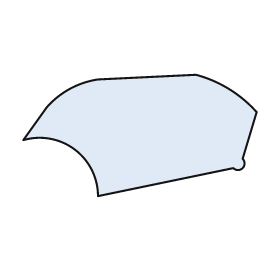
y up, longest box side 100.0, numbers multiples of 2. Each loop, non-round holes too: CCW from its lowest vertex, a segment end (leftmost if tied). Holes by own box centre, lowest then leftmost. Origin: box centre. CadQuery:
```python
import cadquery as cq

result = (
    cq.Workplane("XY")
    .moveTo(-18.0, -26.0)
    .lineTo(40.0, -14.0)
    .threePointArc((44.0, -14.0), (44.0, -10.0))
    .lineTo(50.0, 10.0)
    .threePointArc((38.0, 20.0), (24.0, 26.0))
    .lineTo(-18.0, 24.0)
    .threePointArc((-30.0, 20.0), (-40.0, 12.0))
    .lineTo(-50.0, -2.0)
    .threePointArc((-28.0, -6.0), (-18.0, -26.0))
    .close()
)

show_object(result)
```